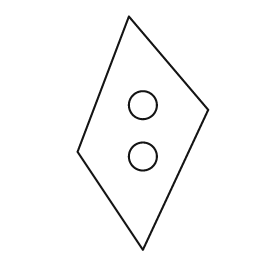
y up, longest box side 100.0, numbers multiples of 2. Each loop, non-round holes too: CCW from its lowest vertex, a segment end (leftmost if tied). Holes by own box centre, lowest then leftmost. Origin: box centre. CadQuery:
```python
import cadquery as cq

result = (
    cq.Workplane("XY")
    .moveTo(0.0, -50.0)
    .lineTo(28.0, 10.0)
    .lineTo(-6.0, 50.0)
    .lineTo(-28.0, -8.0)
    .close()
    .moveTo(0.0, -10.0)
    .circle(6.0)
    .moveTo(0.0, 12.0)
    .circle(6.0)
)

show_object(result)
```